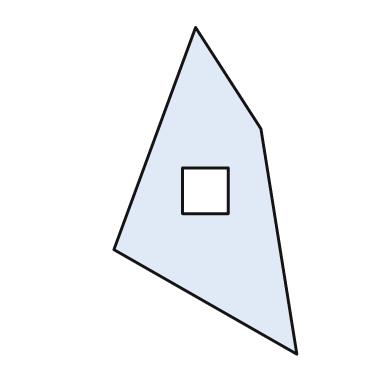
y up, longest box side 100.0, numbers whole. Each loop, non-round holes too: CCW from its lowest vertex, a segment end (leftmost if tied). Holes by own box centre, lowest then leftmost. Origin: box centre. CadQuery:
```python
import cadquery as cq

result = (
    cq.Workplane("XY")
    .moveTo(28.0, -50.0)
    .lineTo(17.0, 19.0)
    .lineTo(-3.0, 50.0)
    .lineTo(-28.0, -18.0)
    .close()
    .moveTo(-7.0, -7.0)
    .lineTo(7.0, -7.0)
    .lineTo(7.0, 7.0)
    .lineTo(-7.0, 7.0)
    .close()
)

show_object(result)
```